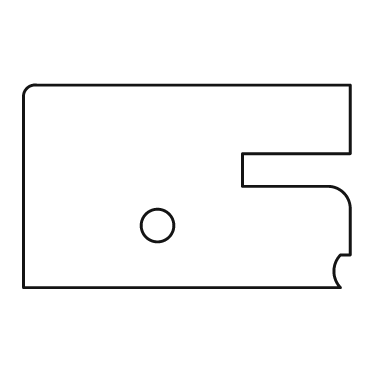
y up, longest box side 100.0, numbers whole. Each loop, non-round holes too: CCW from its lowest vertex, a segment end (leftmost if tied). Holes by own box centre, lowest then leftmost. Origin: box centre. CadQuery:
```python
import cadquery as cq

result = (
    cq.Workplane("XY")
    .moveTo(-50.0, -31.0)
    .lineTo(47.0, -31.0)
    .threePointArc((45.0, -26.0), (47.0, -21.0))
    .lineTo(50.0, -21.0)
    .lineTo(50.0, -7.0)
    .threePointArc((48.0, -2.0), (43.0, 0.0))
    .lineTo(17.0, 0.0)
    .lineTo(17.0, 10.0)
    .lineTo(50.0, 10.0)
    .lineTo(50.0, 31.0)
    .lineTo(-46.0, 31.0)
    .threePointArc((-49.0, 30.0), (-50.0, 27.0))
    .close()
    .moveTo(-9.0, -12.0)
    .circle(5.0)
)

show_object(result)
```